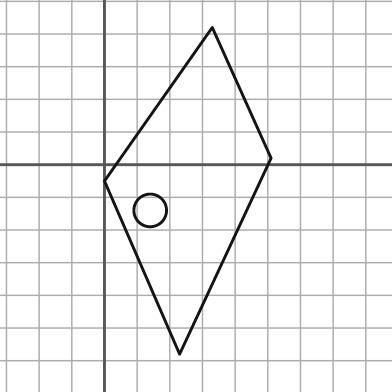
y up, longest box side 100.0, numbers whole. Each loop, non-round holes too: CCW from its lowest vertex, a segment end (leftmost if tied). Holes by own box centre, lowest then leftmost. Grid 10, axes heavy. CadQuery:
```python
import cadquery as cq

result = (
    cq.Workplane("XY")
    .moveTo(23.0, -58.0)
    .lineTo(51.0, 2.0)
    .lineTo(33.0, 42.0)
    .lineTo(0.0, -5.0)
    .close()
    .moveTo(14.0, -14.0)
    .circle(5.0)
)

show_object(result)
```